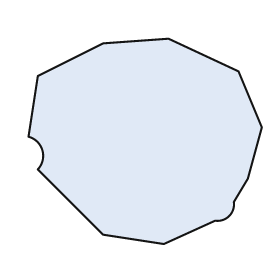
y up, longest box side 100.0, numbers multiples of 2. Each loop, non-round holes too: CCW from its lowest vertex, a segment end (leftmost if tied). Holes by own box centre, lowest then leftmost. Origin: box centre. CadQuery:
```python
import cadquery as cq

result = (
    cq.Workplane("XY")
    .moveTo(8.0, -44.0)
    .lineTo(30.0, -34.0)
    .threePointArc((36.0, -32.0), (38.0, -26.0))
    .lineTo(44.0, -16.0)
    .lineTo(50.0, 6.0)
    .lineTo(40.0, 30.0)
    .lineTo(10.0, 44.0)
    .lineTo(-18.0, 42.0)
    .lineTo(-46.0, 28.0)
    .lineTo(-50.0, 2.0)
    .threePointArc((-44.0, -4.0), (-46.0, -12.0))
    .lineTo(-18.0, -40.0)
    .close()
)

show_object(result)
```